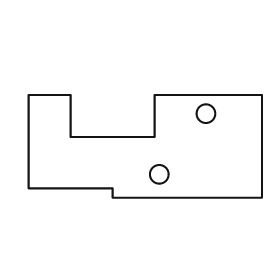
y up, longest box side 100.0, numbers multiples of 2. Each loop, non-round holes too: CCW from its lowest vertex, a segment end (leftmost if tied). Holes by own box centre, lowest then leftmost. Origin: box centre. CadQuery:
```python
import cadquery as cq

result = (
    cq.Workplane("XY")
    .moveTo(-14.0, -22.0)
    .lineTo(50.0, -22.0)
    .lineTo(50.0, 22.0)
    .lineTo(4.0, 22.0)
    .lineTo(4.0, 4.0)
    .lineTo(-32.0, 4.0)
    .lineTo(-32.0, 22.0)
    .lineTo(-50.0, 22.0)
    .lineTo(-50.0, -18.0)
    .lineTo(-14.0, -18.0)
    .close()
    .moveTo(6.0, -12.0)
    .circle(4.0)
    .moveTo(26.0, 14.0)
    .circle(4.0)
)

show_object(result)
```